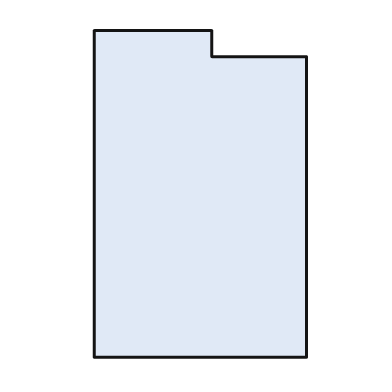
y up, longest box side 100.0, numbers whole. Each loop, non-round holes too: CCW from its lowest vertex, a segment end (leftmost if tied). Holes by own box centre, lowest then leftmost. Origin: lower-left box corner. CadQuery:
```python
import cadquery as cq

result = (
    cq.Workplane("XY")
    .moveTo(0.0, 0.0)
    .lineTo(65.0, 0.0)
    .lineTo(65.0, 92.0)
    .lineTo(36.0, 92.0)
    .lineTo(36.0, 100.0)
    .lineTo(0.0, 100.0)
    .close()
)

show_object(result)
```